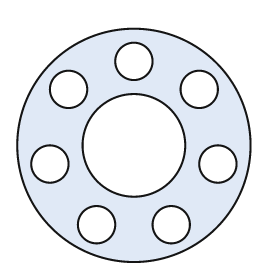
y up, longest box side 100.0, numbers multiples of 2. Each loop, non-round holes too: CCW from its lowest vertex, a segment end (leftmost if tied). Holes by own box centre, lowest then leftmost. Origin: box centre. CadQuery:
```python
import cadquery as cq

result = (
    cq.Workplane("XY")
    .moveTo(0.0, 0.0)
    .circle(50.0)
    .moveTo(-16.0, -34.0)
    .circle(8.0)
    .moveTo(16.0, -34.0)
    .circle(8.0)
    .moveTo(-36.0, -8.0)
    .circle(8.0)
    .moveTo(36.0, -8.0)
    .circle(8.0)
    .moveTo(0.0, 0.0)
    .circle(22.0)
    .moveTo(-28.0, 24.0)
    .circle(8.0)
    .moveTo(28.0, 24.0)
    .circle(8.0)
    .moveTo(0.0, 36.0)
    .circle(8.0)
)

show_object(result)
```